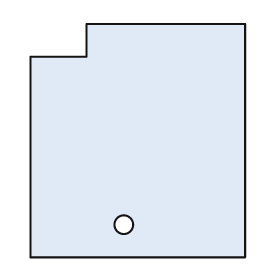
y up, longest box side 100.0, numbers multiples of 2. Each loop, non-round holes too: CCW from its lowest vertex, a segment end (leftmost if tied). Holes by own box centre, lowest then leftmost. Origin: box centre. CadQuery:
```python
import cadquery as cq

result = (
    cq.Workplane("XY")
    .moveTo(-46.0, -50.0)
    .lineTo(46.0, -50.0)
    .lineTo(46.0, 50.0)
    .lineTo(-22.0, 50.0)
    .lineTo(-22.0, 36.0)
    .lineTo(-46.0, 36.0)
    .close()
    .moveTo(-6.0, -36.0)
    .circle(4.0)
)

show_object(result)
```